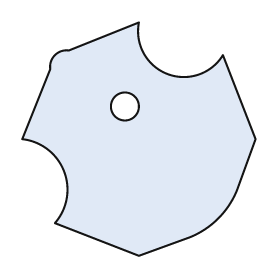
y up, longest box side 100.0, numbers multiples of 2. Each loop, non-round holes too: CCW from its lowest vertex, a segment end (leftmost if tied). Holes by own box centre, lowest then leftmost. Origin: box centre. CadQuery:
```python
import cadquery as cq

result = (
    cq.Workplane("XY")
    .moveTo(0.0, -50.0)
    .lineTo(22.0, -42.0)
    .threePointArc((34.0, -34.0), (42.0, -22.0))
    .lineTo(50.0, 0.0)
    .lineTo(36.0, 36.0)
    .threePointArc((12.0, 28.0), (0.0, 50.0))
    .lineTo(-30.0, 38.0)
    .threePointArc((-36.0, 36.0), (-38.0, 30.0))
    .lineTo(-50.0, 0.0)
    .threePointArc((-32.0, -14.0), (-36.0, -36.0))
    .close()
    .moveTo(-6.0, 14.0)
    .circle(6.0)
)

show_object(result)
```